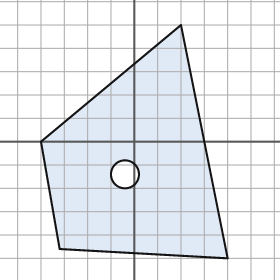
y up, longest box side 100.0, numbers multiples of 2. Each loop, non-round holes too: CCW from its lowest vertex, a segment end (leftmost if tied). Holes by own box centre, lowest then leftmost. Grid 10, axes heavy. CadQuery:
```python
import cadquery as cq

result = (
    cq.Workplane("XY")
    .moveTo(40.0, -50.0)
    .lineTo(20.0, 50.0)
    .lineTo(-40.0, 0.0)
    .lineTo(-32.0, -46.0)
    .close()
    .moveTo(-4.0, -14.0)
    .circle(6.0)
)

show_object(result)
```